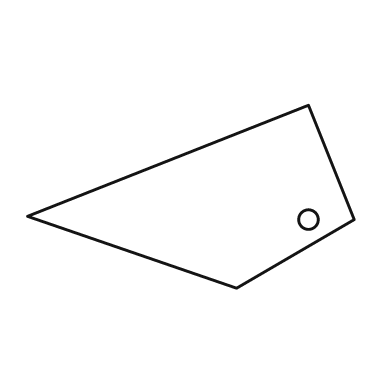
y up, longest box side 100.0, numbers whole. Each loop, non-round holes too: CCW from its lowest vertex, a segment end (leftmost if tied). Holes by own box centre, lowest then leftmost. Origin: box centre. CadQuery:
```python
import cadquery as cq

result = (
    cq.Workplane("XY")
    .moveTo(14.0, -28.0)
    .lineTo(50.0, -7.0)
    .lineTo(36.0, 28.0)
    .lineTo(-50.0, -6.0)
    .close()
    .moveTo(36.0, -7.0)
    .circle(3.0)
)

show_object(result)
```